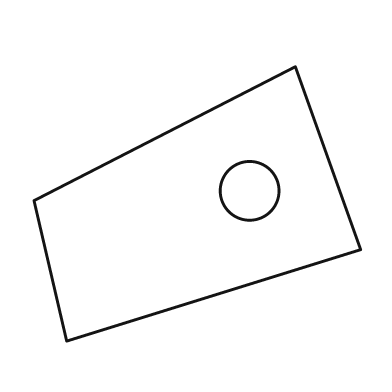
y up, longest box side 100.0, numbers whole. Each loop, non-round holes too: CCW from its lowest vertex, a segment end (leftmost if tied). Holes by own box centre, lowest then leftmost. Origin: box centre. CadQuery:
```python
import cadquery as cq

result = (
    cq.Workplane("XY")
    .moveTo(-40.0, -42.0)
    .lineTo(50.0, -14.0)
    .lineTo(30.0, 42.0)
    .lineTo(-50.0, 1.0)
    .close()
    .moveTo(16.0, 4.0)
    .circle(9.0)
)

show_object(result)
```